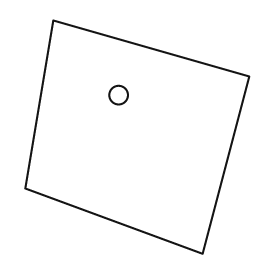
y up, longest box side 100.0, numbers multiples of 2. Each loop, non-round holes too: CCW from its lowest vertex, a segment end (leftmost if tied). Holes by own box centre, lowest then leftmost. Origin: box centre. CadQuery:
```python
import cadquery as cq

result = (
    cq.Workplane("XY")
    .moveTo(28.0, -50.0)
    .lineTo(48.0, 26.0)
    .lineTo(-36.0, 50.0)
    .lineTo(-48.0, -22.0)
    .close()
    .moveTo(-8.0, 18.0)
    .circle(4.0)
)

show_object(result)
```